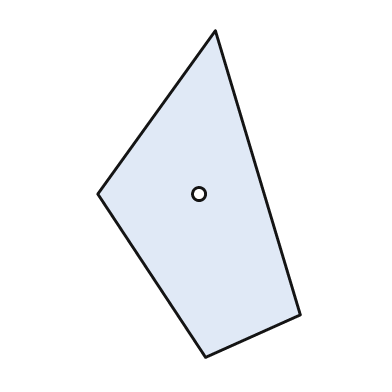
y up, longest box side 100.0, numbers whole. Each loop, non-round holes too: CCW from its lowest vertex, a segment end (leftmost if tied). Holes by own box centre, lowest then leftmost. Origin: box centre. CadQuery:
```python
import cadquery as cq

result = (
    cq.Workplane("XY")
    .moveTo(2.0, -50.0)
    .lineTo(31.0, -37.0)
    .lineTo(5.0, 50.0)
    .lineTo(-31.0, 0.0)
    .close()
    .moveTo(0.0, 0.0)
    .circle(2.0)
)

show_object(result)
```